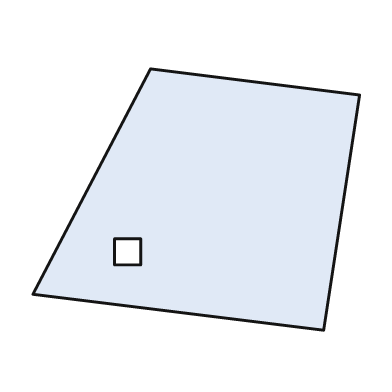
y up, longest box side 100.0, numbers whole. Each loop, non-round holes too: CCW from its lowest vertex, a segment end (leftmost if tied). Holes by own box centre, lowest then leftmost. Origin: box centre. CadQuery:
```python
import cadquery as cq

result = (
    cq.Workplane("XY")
    .moveTo(39.0, -40.0)
    .lineTo(50.0, 32.0)
    .lineTo(-14.0, 40.0)
    .lineTo(-50.0, -29.0)
    .close()
    .moveTo(-25.0, -20.0)
    .lineTo(-17.0, -20.0)
    .lineTo(-17.0, -12.0)
    .lineTo(-25.0, -12.0)
    .close()
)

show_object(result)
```